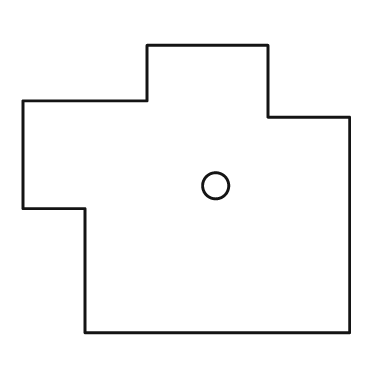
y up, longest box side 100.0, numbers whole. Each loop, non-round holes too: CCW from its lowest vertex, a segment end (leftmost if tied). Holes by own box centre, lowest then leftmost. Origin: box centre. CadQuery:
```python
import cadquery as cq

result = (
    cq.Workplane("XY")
    .moveTo(-31.0, -44.0)
    .lineTo(50.0, -44.0)
    .lineTo(50.0, 22.0)
    .lineTo(25.0, 22.0)
    .lineTo(25.0, 44.0)
    .lineTo(-12.0, 44.0)
    .lineTo(-12.0, 27.0)
    .lineTo(-50.0, 27.0)
    .lineTo(-50.0, -6.0)
    .lineTo(-31.0, -6.0)
    .close()
    .moveTo(9.0, 1.0)
    .circle(4.0)
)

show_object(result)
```